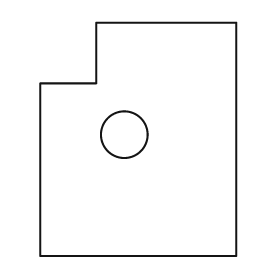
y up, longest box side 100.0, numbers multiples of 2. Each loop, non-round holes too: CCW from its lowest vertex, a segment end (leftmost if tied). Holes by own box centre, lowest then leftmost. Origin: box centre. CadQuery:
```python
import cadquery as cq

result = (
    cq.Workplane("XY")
    .moveTo(-42.0, -50.0)
    .lineTo(42.0, -50.0)
    .lineTo(42.0, 50.0)
    .lineTo(-18.0, 50.0)
    .lineTo(-18.0, 24.0)
    .lineTo(-42.0, 24.0)
    .close()
    .moveTo(-6.0, 2.0)
    .circle(10.0)
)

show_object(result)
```